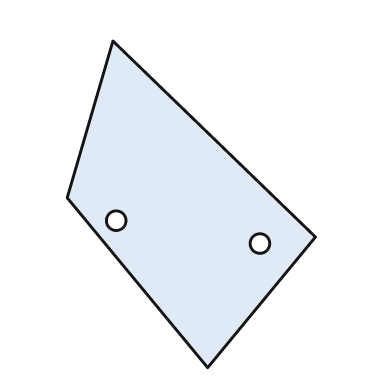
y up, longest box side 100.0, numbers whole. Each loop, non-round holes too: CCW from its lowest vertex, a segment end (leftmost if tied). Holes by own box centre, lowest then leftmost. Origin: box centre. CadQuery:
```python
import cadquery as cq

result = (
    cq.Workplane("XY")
    .moveTo(5.0, -50.0)
    .lineTo(38.0, -10.0)
    .lineTo(-24.0, 50.0)
    .lineTo(-38.0, 2.0)
    .close()
    .moveTo(21.0, -12.0)
    .circle(3.0)
    .moveTo(-23.0, -5.0)
    .circle(3.0)
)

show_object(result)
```